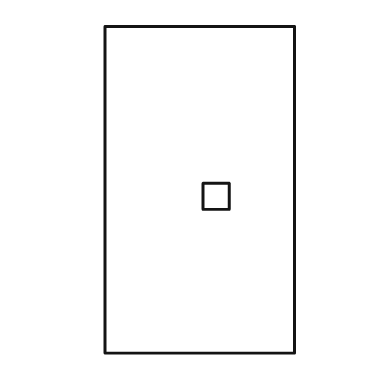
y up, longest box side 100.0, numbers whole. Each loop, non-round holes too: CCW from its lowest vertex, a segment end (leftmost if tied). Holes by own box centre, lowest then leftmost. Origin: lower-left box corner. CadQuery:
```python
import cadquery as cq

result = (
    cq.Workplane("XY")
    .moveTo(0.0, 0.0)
    .lineTo(58.0, 0.0)
    .lineTo(58.0, 100.0)
    .lineTo(0.0, 100.0)
    .close()
    .moveTo(30.0, 44.0)
    .lineTo(38.0, 44.0)
    .lineTo(38.0, 52.0)
    .lineTo(30.0, 52.0)
    .close()
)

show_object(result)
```